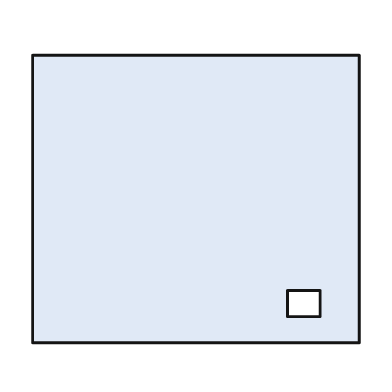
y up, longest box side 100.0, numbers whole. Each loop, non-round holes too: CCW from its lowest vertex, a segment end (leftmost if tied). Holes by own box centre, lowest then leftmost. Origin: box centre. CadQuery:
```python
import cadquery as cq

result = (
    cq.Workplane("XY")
    .moveTo(-50.0, -44.0)
    .lineTo(50.0, -44.0)
    .lineTo(50.0, 44.0)
    .lineTo(-50.0, 44.0)
    .close()
    .moveTo(28.0, -36.0)
    .lineTo(38.0, -36.0)
    .lineTo(38.0, -28.0)
    .lineTo(28.0, -28.0)
    .close()
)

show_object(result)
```